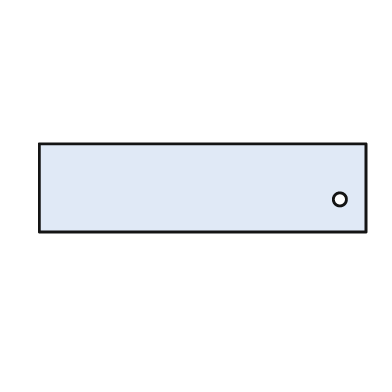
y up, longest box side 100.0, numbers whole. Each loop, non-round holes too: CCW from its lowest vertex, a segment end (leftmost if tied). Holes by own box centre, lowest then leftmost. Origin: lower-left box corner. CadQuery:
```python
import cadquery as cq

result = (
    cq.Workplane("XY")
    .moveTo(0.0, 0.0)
    .lineTo(100.0, 0.0)
    .lineTo(100.0, 27.0)
    .lineTo(0.0, 27.0)
    .close()
    .moveTo(92.0, 10.0)
    .circle(2.0)
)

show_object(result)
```